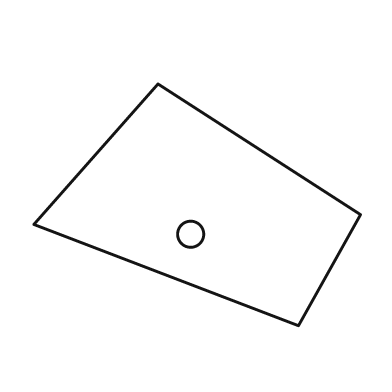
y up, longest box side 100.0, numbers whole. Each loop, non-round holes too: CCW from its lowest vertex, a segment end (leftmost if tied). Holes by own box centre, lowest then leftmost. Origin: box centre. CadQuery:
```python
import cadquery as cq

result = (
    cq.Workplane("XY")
    .moveTo(31.0, -37.0)
    .lineTo(50.0, -3.0)
    .lineTo(-12.0, 37.0)
    .lineTo(-50.0, -6.0)
    .close()
    .moveTo(-2.0, -9.0)
    .circle(4.0)
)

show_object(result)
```